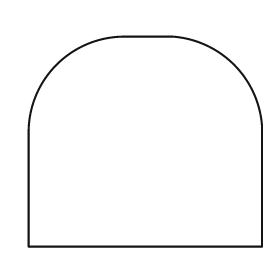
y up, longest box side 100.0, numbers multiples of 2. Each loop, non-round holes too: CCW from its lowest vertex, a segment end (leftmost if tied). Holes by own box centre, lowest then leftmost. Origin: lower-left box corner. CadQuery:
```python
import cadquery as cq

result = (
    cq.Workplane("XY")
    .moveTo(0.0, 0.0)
    .lineTo(100.0, 0.0)
    .lineTo(100.0, 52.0)
    .threePointArc((88.0, 78.0), (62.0, 90.0))
    .lineTo(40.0, 90.0)
    .threePointArc((12.0, 78.0), (0.0, 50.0))
    .close()
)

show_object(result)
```